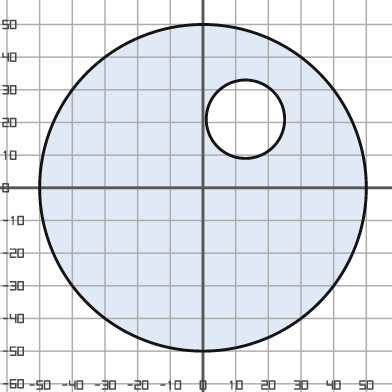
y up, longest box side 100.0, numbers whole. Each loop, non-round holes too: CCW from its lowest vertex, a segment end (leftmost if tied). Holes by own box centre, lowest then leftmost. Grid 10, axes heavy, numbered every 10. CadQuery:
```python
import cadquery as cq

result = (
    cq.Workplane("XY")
    .moveTo(0.0, 0.0)
    .circle(50.0)
    .moveTo(13.0, 21.0)
    .circle(12.0)
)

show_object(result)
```